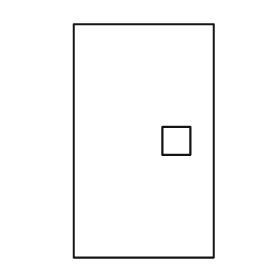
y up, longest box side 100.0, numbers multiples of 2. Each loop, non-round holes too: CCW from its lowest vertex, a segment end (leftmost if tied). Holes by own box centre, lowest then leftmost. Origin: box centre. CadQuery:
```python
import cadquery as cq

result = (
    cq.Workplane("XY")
    .moveTo(-30.0, -50.0)
    .lineTo(30.0, -50.0)
    .lineTo(30.0, 50.0)
    .lineTo(-30.0, 50.0)
    .close()
    .moveTo(8.0, -6.0)
    .lineTo(20.0, -6.0)
    .lineTo(20.0, 6.0)
    .lineTo(8.0, 6.0)
    .close()
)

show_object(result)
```